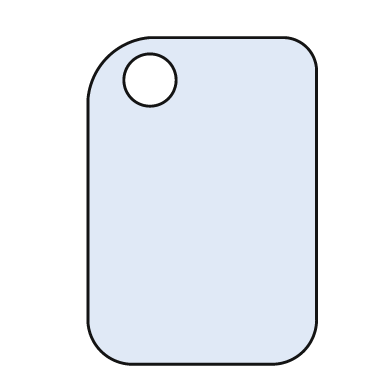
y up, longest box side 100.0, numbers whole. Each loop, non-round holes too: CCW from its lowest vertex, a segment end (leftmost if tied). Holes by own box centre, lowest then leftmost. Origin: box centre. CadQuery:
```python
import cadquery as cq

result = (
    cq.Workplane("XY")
    .moveTo(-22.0, -50.0)
    .lineTo(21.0, -50.0)
    .threePointArc((31.0, -46.0), (35.0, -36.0))
    .lineTo(35.0, 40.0)
    .threePointArc((32.0, 47.0), (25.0, 50.0))
    .lineTo(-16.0, 50.0)
    .threePointArc((-29.0, 44.0), (-35.0, 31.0))
    .lineTo(-35.0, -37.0)
    .threePointArc((-31.0, -46.0), (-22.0, -50.0))
    .close()
    .moveTo(-16.0, 37.0)
    .circle(8.0)
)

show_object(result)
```